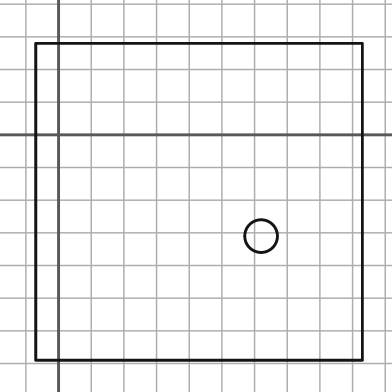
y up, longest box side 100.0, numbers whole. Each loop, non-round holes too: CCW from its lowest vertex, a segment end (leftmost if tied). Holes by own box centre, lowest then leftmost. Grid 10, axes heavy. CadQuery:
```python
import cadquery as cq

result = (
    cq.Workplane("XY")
    .moveTo(-7.0, -69.0)
    .lineTo(93.0, -69.0)
    .lineTo(93.0, 28.0)
    .lineTo(-7.0, 28.0)
    .close()
    .moveTo(62.0, -31.0)
    .circle(5.0)
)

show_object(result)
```